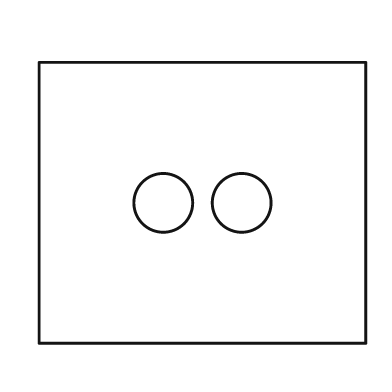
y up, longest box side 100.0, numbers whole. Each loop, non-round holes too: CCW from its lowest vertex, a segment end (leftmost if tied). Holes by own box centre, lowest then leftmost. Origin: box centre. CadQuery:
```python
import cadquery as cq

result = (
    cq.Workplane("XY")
    .moveTo(-50.0, -43.0)
    .lineTo(50.0, -43.0)
    .lineTo(50.0, 43.0)
    .lineTo(-50.0, 43.0)
    .close()
    .moveTo(-12.0, 0.0)
    .circle(9.0)
    .moveTo(12.0, 0.0)
    .circle(9.0)
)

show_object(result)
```